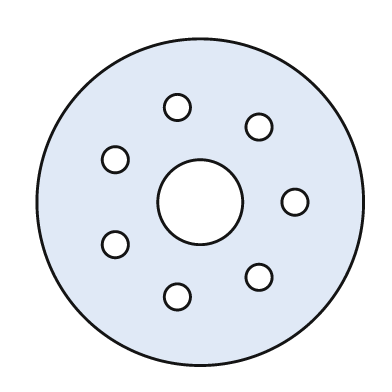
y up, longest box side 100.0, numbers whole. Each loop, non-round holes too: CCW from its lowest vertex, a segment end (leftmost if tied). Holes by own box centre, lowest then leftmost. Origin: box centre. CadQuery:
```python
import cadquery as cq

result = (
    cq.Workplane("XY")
    .moveTo(0.0, 0.0)
    .circle(50.0)
    .moveTo(-7.0, -29.0)
    .circle(4.0)
    .moveTo(18.0, -23.0)
    .circle(4.0)
    .moveTo(-26.0, -13.0)
    .circle(4.0)
    .moveTo(0.0, 0.0)
    .circle(13.0)
    .moveTo(29.0, 0.0)
    .circle(4.0)
    .moveTo(-26.0, 13.0)
    .circle(4.0)
    .moveTo(18.0, 23.0)
    .circle(4.0)
    .moveTo(-7.0, 29.0)
    .circle(4.0)
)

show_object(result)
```